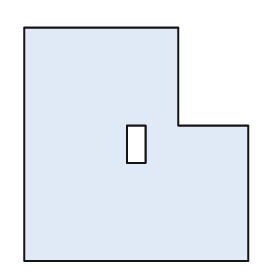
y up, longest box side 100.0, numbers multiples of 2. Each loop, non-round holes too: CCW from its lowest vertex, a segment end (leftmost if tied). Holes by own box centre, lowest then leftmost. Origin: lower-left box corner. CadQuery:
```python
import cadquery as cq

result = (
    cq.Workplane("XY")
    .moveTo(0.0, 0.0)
    .lineTo(96.0, 0.0)
    .lineTo(96.0, 58.0)
    .lineTo(66.0, 58.0)
    .lineTo(66.0, 100.0)
    .lineTo(0.0, 100.0)
    .close()
    .moveTo(44.0, 42.0)
    .lineTo(52.0, 42.0)
    .lineTo(52.0, 58.0)
    .lineTo(44.0, 58.0)
    .close()
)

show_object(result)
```